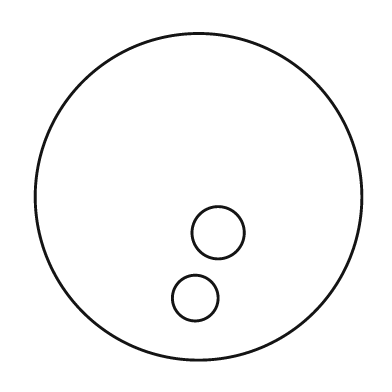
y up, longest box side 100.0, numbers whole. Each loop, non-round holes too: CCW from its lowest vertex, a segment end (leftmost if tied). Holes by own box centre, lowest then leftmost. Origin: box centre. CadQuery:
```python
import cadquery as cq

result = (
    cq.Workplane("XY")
    .moveTo(0.0, 0.0)
    .circle(50.0)
    .moveTo(-1.0, -31.0)
    .circle(7.0)
    .moveTo(6.0, -11.0)
    .circle(8.0)
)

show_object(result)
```